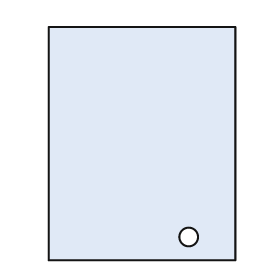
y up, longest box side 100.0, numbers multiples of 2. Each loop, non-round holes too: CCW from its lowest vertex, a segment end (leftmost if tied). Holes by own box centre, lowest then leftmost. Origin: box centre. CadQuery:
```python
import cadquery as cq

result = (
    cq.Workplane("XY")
    .moveTo(-40.0, -50.0)
    .lineTo(40.0, -50.0)
    .lineTo(40.0, 50.0)
    .lineTo(-40.0, 50.0)
    .close()
    .moveTo(20.0, -40.0)
    .circle(4.0)
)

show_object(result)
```